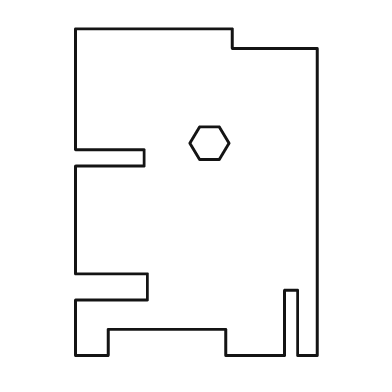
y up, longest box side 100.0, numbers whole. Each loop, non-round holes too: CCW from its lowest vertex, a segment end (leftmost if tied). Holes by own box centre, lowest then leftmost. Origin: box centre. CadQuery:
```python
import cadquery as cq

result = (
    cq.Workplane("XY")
    .moveTo(-37.0, -50.0)
    .lineTo(-27.0, -50.0)
    .lineTo(-27.0, -42.0)
    .lineTo(9.0, -42.0)
    .lineTo(9.0, -50.0)
    .lineTo(27.0, -50.0)
    .lineTo(27.0, -30.0)
    .lineTo(31.0, -30.0)
    .lineTo(31.0, -50.0)
    .lineTo(37.0, -50.0)
    .lineTo(37.0, 44.0)
    .lineTo(11.0, 44.0)
    .lineTo(11.0, 50.0)
    .lineTo(-37.0, 50.0)
    .lineTo(-37.0, 13.0)
    .lineTo(-16.0, 13.0)
    .lineTo(-16.0, 8.0)
    .lineTo(-37.0, 8.0)
    .lineTo(-37.0, -25.0)
    .lineTo(-15.0, -25.0)
    .lineTo(-15.0, -33.0)
    .lineTo(-37.0, -33.0)
    .close()
    .moveTo(1.0, 10.0)
    .lineTo(7.0, 10.0)
    .lineTo(10.0, 15.0)
    .lineTo(7.0, 20.0)
    .lineTo(1.0, 20.0)
    .lineTo(-2.0, 15.0)
    .close()
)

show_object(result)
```